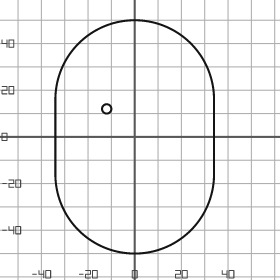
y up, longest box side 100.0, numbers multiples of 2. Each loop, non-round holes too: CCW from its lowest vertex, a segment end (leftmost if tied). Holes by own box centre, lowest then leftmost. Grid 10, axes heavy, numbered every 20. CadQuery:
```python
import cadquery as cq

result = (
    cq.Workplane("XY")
    .moveTo(-34.0, -16.0)
    .threePointArc((0.0, -50.0), (34.0, -16.0))
    .lineTo(34.0, 16.0)
    .threePointArc((0.0, 50.0), (-34.0, 16.0))
    .close()
    .moveTo(-12.0, 12.0)
    .circle(2.0)
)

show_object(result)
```